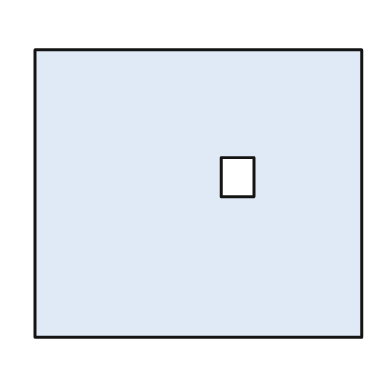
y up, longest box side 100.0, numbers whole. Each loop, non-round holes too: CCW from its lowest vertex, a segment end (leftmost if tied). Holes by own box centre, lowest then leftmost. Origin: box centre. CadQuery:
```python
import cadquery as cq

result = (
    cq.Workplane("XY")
    .moveTo(-50.0, -44.0)
    .lineTo(50.0, -44.0)
    .lineTo(50.0, 44.0)
    .lineTo(-50.0, 44.0)
    .close()
    .moveTo(7.0, -1.0)
    .lineTo(17.0, -1.0)
    .lineTo(17.0, 11.0)
    .lineTo(7.0, 11.0)
    .close()
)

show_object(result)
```